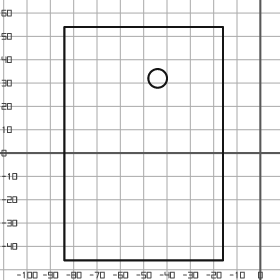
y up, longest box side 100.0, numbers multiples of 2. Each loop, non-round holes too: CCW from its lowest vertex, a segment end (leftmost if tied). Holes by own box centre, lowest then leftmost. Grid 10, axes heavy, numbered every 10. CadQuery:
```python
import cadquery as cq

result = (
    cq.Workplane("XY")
    .moveTo(-84.0, -46.0)
    .lineTo(-16.0, -46.0)
    .lineTo(-16.0, 54.0)
    .lineTo(-84.0, 54.0)
    .close()
    .moveTo(-44.0, 32.0)
    .circle(4.0)
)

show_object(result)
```